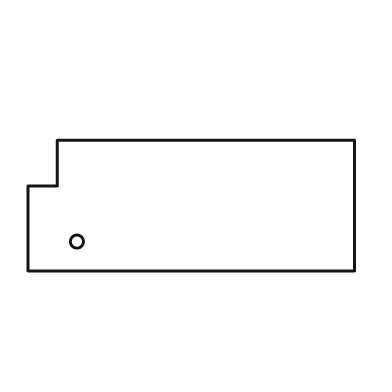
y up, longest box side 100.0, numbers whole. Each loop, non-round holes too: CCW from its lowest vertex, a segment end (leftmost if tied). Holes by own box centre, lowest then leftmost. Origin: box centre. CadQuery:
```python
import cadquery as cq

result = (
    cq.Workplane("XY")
    .moveTo(-50.0, -20.0)
    .lineTo(50.0, -20.0)
    .lineTo(50.0, 20.0)
    .lineTo(-41.0, 20.0)
    .lineTo(-41.0, 6.0)
    .lineTo(-50.0, 6.0)
    .close()
    .moveTo(-35.0, -11.0)
    .circle(2.0)
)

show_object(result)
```